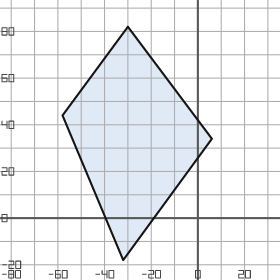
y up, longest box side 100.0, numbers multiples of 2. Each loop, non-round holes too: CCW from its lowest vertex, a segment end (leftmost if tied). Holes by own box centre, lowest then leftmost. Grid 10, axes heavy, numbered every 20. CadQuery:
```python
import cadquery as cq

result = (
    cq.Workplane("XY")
    .moveTo(-32.0, -18.0)
    .lineTo(6.0, 34.0)
    .lineTo(-30.0, 82.0)
    .lineTo(-58.0, 44.0)
    .close()
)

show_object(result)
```